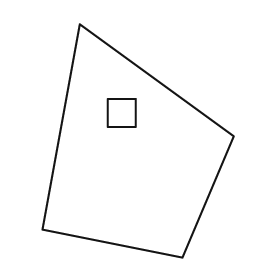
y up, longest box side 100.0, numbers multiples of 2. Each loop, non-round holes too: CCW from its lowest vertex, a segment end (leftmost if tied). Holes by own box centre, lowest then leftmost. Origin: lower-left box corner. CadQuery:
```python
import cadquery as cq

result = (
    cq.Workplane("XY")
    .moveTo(60.0, 0.0)
    .lineTo(82.0, 52.0)
    .lineTo(16.0, 100.0)
    .lineTo(0.0, 12.0)
    .close()
    .moveTo(28.0, 56.0)
    .lineTo(40.0, 56.0)
    .lineTo(40.0, 68.0)
    .lineTo(28.0, 68.0)
    .close()
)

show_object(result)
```